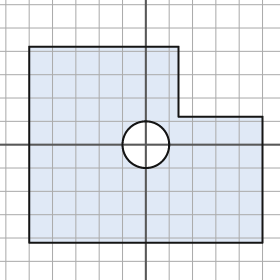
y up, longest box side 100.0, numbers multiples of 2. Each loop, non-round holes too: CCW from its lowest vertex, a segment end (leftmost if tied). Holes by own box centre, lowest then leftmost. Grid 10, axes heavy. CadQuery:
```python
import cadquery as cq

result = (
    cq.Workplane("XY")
    .moveTo(-50.0, -42.0)
    .lineTo(50.0, -42.0)
    .lineTo(50.0, 12.0)
    .lineTo(14.0, 12.0)
    .lineTo(14.0, 42.0)
    .lineTo(-50.0, 42.0)
    .close()
    .moveTo(0.0, 0.0)
    .circle(10.0)
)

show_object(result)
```